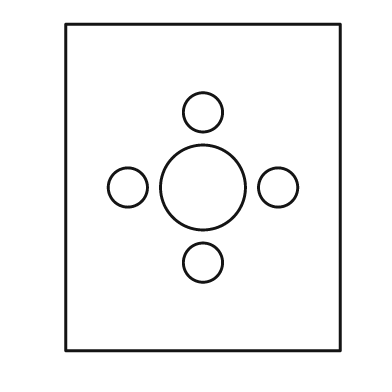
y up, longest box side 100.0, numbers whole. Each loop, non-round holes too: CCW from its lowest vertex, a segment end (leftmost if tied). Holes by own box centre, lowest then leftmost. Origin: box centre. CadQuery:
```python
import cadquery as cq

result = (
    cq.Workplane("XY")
    .moveTo(-42.0, -50.0)
    .lineTo(42.0, -50.0)
    .lineTo(42.0, 50.0)
    .lineTo(-42.0, 50.0)
    .close()
    .moveTo(0.0, -23.0)
    .circle(6.0)
    .moveTo(-23.0, 0.0)
    .circle(6.0)
    .moveTo(0.0, 0.0)
    .circle(13.0)
    .moveTo(23.0, 0.0)
    .circle(6.0)
    .moveTo(0.0, 23.0)
    .circle(6.0)
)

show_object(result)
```